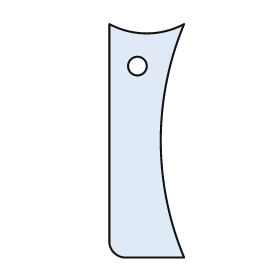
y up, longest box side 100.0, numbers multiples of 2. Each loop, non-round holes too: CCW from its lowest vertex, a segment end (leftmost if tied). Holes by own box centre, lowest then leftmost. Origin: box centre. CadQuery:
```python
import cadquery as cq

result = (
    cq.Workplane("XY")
    .moveTo(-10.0, -50.0)
    .lineTo(16.0, -50.0)
    .threePointArc((6.0, 0.0), (16.0, 50.0))
    .threePointArc((0.0, 46.0), (-16.0, 50.0))
    .lineTo(-16.0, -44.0)
    .threePointArc((-14.0, -48.0), (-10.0, -50.0))
    .close()
    .moveTo(-4.0, 32.0)
    .circle(4.0)
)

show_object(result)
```